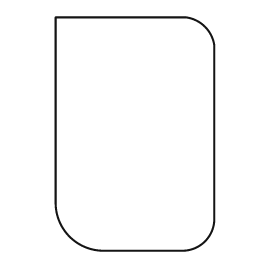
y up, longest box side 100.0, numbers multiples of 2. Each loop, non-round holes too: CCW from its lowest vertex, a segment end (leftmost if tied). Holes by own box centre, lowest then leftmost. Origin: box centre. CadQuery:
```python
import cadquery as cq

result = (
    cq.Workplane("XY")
    .moveTo(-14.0, -50.0)
    .lineTo(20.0, -50.0)
    .threePointArc((30.0, -46.0), (34.0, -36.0))
    .lineTo(34.0, 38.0)
    .threePointArc((30.0, 46.0), (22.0, 50.0))
    .lineTo(-34.0, 50.0)
    .lineTo(-34.0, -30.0)
    .threePointArc((-28.0, -44.0), (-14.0, -50.0))
    .close()
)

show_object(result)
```